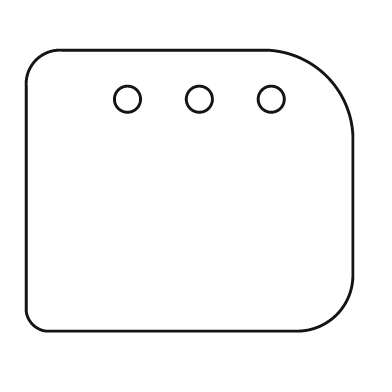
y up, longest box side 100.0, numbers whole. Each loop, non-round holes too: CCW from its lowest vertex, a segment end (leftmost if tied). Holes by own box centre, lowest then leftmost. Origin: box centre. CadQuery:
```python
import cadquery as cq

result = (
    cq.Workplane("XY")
    .moveTo(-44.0, -43.0)
    .lineTo(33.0, -43.0)
    .threePointArc((45.0, -38.0), (50.0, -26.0))
    .lineTo(50.0, 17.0)
    .threePointArc((42.0, 35.0), (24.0, 43.0))
    .lineTo(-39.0, 43.0)
    .threePointArc((-47.0, 40.0), (-50.0, 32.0))
    .lineTo(-50.0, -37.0)
    .threePointArc((-48.0, -41.0), (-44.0, -43.0))
    .close()
    .moveTo(-19.0, 28.0)
    .circle(4.0)
    .moveTo(3.0, 28.0)
    .circle(4.0)
    .moveTo(25.0, 28.0)
    .circle(4.0)
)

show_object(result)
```